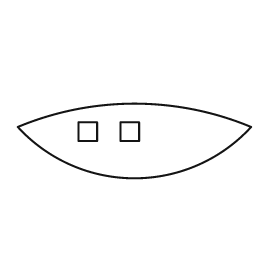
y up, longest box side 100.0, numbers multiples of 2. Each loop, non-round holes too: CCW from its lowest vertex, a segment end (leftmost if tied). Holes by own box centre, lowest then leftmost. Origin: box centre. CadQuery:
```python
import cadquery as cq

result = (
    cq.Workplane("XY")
    .moveTo(-50.0, 6.0)
    .threePointArc((0.0, -16.0), (50.0, 6.0))
    .threePointArc((0.0, 16.0), (-50.0, 6.0))
    .close()
    .moveTo(-24.0, 0.0)
    .lineTo(-16.0, 0.0)
    .lineTo(-16.0, 8.0)
    .lineTo(-24.0, 8.0)
    .close()
    .moveTo(-6.0, 0.0)
    .lineTo(2.0, 0.0)
    .lineTo(2.0, 8.0)
    .lineTo(-6.0, 8.0)
    .close()
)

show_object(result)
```